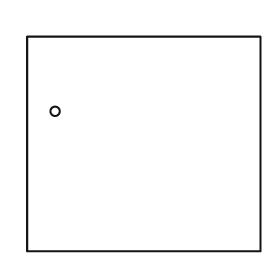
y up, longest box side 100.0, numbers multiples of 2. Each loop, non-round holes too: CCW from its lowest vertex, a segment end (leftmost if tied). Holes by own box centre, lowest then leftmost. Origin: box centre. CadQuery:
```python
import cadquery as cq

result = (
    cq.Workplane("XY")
    .moveTo(-50.0, -46.0)
    .lineTo(50.0, -46.0)
    .lineTo(50.0, 46.0)
    .lineTo(-50.0, 46.0)
    .close()
    .moveTo(-38.0, 14.0)
    .circle(2.0)
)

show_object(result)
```